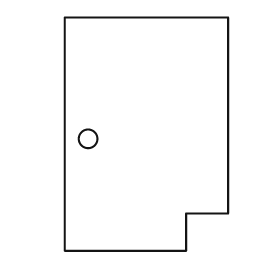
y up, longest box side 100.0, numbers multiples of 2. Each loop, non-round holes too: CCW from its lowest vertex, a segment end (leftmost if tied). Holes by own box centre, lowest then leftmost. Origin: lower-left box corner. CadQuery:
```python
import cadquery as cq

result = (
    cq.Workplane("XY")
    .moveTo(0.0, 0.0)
    .lineTo(52.0, 0.0)
    .lineTo(52.0, 16.0)
    .lineTo(70.0, 16.0)
    .lineTo(70.0, 100.0)
    .lineTo(0.0, 100.0)
    .close()
    .moveTo(10.0, 48.0)
    .circle(4.0)
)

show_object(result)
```